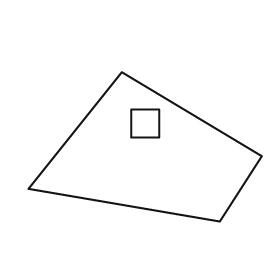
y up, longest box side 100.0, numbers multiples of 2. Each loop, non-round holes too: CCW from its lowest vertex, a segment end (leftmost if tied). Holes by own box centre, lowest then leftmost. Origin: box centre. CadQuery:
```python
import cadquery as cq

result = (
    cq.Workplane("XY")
    .moveTo(32.0, -32.0)
    .lineTo(50.0, -4.0)
    .lineTo(-10.0, 32.0)
    .lineTo(-50.0, -18.0)
    .close()
    .moveTo(-6.0, 4.0)
    .lineTo(6.0, 4.0)
    .lineTo(6.0, 16.0)
    .lineTo(-6.0, 16.0)
    .close()
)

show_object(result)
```